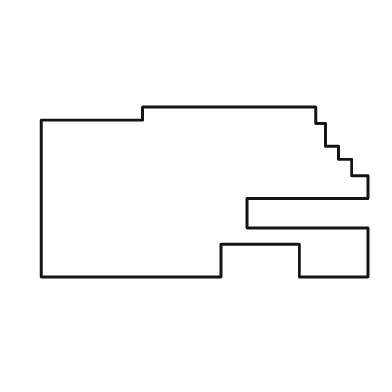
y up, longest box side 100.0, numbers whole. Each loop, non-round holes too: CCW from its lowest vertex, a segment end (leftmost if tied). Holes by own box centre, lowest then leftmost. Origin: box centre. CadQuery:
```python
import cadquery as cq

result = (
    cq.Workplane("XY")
    .moveTo(-50.0, -26.0)
    .lineTo(5.0, -26.0)
    .lineTo(5.0, -16.0)
    .lineTo(29.0, -16.0)
    .lineTo(29.0, -26.0)
    .lineTo(50.0, -26.0)
    .lineTo(50.0, -11.0)
    .lineTo(13.0, -11.0)
    .lineTo(13.0, -2.0)
    .lineTo(50.0, -2.0)
    .lineTo(50.0, 5.0)
    .lineTo(45.0, 5.0)
    .lineTo(45.0, 10.0)
    .lineTo(41.0, 10.0)
    .lineTo(41.0, 14.0)
    .lineTo(37.0, 14.0)
    .lineTo(37.0, 21.0)
    .lineTo(34.0, 21.0)
    .lineTo(34.0, 26.0)
    .lineTo(-19.0, 26.0)
    .lineTo(-19.0, 22.0)
    .lineTo(-50.0, 22.0)
    .close()
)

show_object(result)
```